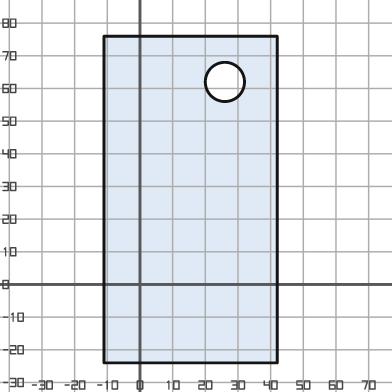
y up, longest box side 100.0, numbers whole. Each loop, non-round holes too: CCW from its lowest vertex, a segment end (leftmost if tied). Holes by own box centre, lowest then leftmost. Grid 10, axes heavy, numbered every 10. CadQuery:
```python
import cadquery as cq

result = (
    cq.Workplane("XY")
    .moveTo(-11.0, -24.0)
    .lineTo(42.0, -24.0)
    .lineTo(42.0, 76.0)
    .lineTo(-11.0, 76.0)
    .close()
    .moveTo(26.0, 62.0)
    .circle(6.0)
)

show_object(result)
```